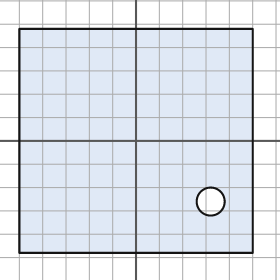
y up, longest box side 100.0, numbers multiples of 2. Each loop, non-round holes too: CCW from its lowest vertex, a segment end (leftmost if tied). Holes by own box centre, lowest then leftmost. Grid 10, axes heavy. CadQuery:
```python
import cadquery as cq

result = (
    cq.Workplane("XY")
    .moveTo(-50.0, -48.0)
    .lineTo(50.0, -48.0)
    .lineTo(50.0, 48.0)
    .lineTo(-50.0, 48.0)
    .close()
    .moveTo(32.0, -26.0)
    .circle(6.0)
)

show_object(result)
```